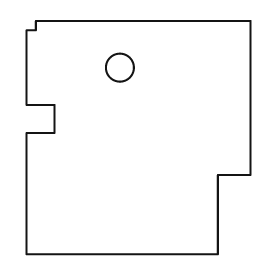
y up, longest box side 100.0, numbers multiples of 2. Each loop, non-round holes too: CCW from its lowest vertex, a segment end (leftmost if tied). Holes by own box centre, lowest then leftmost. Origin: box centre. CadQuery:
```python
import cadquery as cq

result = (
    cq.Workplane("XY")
    .moveTo(-48.0, -50.0)
    .lineTo(34.0, -50.0)
    .lineTo(34.0, -16.0)
    .lineTo(48.0, -16.0)
    .lineTo(48.0, 50.0)
    .lineTo(-44.0, 50.0)
    .lineTo(-44.0, 46.0)
    .lineTo(-48.0, 46.0)
    .lineTo(-48.0, 14.0)
    .lineTo(-36.0, 14.0)
    .lineTo(-36.0, 2.0)
    .lineTo(-48.0, 2.0)
    .close()
    .moveTo(-8.0, 30.0)
    .circle(6.0)
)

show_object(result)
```